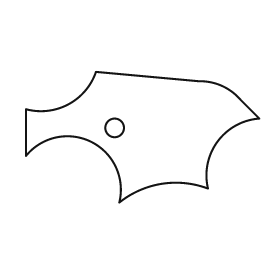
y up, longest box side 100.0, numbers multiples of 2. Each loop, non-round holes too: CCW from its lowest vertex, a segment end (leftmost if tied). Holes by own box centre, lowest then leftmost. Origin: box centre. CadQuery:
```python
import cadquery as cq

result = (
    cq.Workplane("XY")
    .moveTo(-10.0, -28.0)
    .threePointArc((8.0, -20.0), (28.0, -22.0))
    .threePointArc((32.0, -2.0), (50.0, 8.0))
    .lineTo(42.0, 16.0)
    .threePointArc((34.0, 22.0), (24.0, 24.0))
    .lineTo(-20.0, 28.0)
    .threePointArc((-32.0, 14.0), (-50.0, 12.0))
    .lineTo(-50.0, -8.0)
    .threePointArc((-22.0, -2.0), (-10.0, -28.0))
    .close()
    .moveTo(-12.0, 4.0)
    .circle(4.0)
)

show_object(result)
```